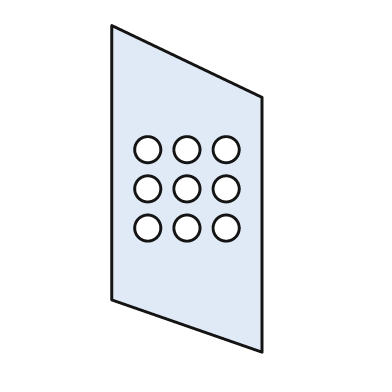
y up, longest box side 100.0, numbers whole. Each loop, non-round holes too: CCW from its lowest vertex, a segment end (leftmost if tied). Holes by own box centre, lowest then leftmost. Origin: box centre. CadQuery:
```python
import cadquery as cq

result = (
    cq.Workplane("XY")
    .moveTo(23.0, -50.0)
    .lineTo(23.0, 28.0)
    .lineTo(-23.0, 50.0)
    .lineTo(-23.0, -34.0)
    .close()
    .moveTo(-12.0, -12.0)
    .circle(4.0)
    .moveTo(0.0, -12.0)
    .circle(4.0)
    .moveTo(12.0, -12.0)
    .circle(4.0)
    .moveTo(-12.0, 0.0)
    .circle(4.0)
    .moveTo(0.0, 0.0)
    .circle(4.0)
    .moveTo(12.0, 0.0)
    .circle(4.0)
    .moveTo(-12.0, 12.0)
    .circle(4.0)
    .moveTo(0.0, 12.0)
    .circle(4.0)
    .moveTo(12.0, 12.0)
    .circle(4.0)
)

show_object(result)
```